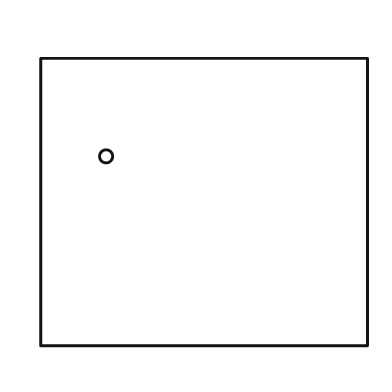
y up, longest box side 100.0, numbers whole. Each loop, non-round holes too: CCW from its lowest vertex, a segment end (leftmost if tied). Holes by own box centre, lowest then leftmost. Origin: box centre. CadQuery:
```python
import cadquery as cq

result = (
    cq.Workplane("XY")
    .moveTo(-50.0, -44.0)
    .lineTo(50.0, -44.0)
    .lineTo(50.0, 44.0)
    .lineTo(-50.0, 44.0)
    .close()
    .moveTo(-30.0, 14.0)
    .circle(2.0)
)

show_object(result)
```